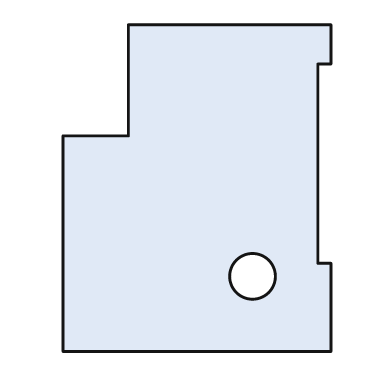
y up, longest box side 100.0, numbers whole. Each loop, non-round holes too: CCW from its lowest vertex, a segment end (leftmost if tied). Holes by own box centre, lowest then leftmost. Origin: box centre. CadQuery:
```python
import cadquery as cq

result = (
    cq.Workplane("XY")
    .moveTo(-41.0, -50.0)
    .lineTo(41.0, -50.0)
    .lineTo(41.0, -23.0)
    .lineTo(37.0, -23.0)
    .lineTo(37.0, 38.0)
    .lineTo(41.0, 38.0)
    .lineTo(41.0, 50.0)
    .lineTo(-21.0, 50.0)
    .lineTo(-21.0, 16.0)
    .lineTo(-41.0, 16.0)
    .close()
    .moveTo(17.0, -27.0)
    .circle(7.0)
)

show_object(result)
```